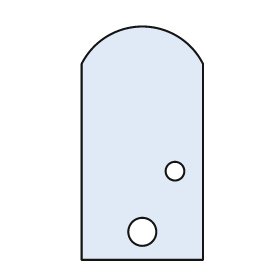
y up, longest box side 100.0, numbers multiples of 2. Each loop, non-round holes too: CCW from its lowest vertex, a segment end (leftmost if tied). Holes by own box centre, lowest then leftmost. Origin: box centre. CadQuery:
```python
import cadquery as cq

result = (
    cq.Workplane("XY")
    .moveTo(-26.0, -50.0)
    .lineTo(26.0, -50.0)
    .lineTo(26.0, 34.0)
    .threePointArc((0.0, 50.0), (-26.0, 34.0))
    .close()
    .moveTo(0.0, -38.0)
    .circle(6.0)
    .moveTo(14.0, -12.0)
    .circle(4.0)
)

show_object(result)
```